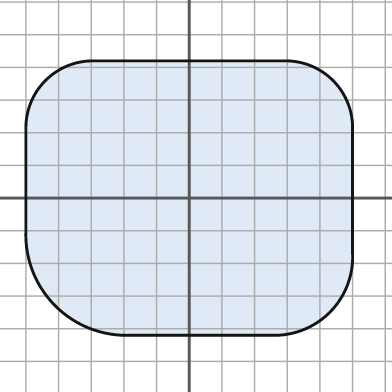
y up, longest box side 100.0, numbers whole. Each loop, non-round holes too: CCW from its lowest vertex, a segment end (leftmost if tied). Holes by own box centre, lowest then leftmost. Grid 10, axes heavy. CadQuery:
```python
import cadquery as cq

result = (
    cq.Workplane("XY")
    .moveTo(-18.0, -42.0)
    .lineTo(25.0, -42.0)
    .threePointArc((43.0, -35.0), (50.0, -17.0))
    .lineTo(50.0, 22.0)
    .threePointArc((44.0, 36.0), (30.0, 42.0))
    .lineTo(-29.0, 42.0)
    .threePointArc((-44.0, 36.0), (-50.0, 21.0))
    .lineTo(-50.0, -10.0)
    .threePointArc((-41.0, -33.0), (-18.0, -42.0))
    .close()
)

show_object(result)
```